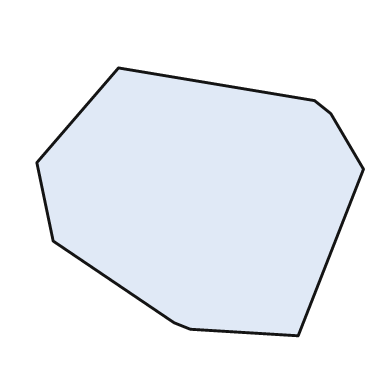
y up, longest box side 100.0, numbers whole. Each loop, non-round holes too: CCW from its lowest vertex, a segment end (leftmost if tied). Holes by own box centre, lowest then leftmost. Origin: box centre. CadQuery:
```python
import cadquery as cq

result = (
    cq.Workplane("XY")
    .moveTo(30.0, -41.0)
    .lineTo(50.0, 10.0)
    .lineTo(40.0, 27.0)
    .lineTo(35.0, 31.0)
    .lineTo(-25.0, 41.0)
    .lineTo(-50.0, 12.0)
    .lineTo(-45.0, -12.0)
    .lineTo(-8.0, -37.0)
    .lineTo(-3.0, -39.0)
    .close()
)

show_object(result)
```